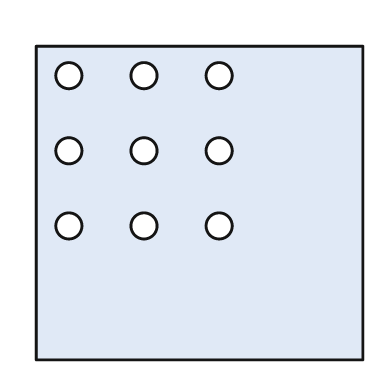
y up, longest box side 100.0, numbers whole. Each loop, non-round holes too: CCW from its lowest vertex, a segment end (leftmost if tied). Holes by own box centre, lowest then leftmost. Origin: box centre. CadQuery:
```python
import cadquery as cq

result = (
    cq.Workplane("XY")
    .moveTo(-50.0, -48.0)
    .lineTo(50.0, -48.0)
    .lineTo(50.0, 48.0)
    .lineTo(-50.0, 48.0)
    .close()
    .moveTo(-40.0, -7.0)
    .circle(4.0)
    .moveTo(-17.0, -7.0)
    .circle(4.0)
    .moveTo(6.0, -7.0)
    .circle(4.0)
    .moveTo(-40.0, 16.0)
    .circle(4.0)
    .moveTo(-17.0, 16.0)
    .circle(4.0)
    .moveTo(6.0, 16.0)
    .circle(4.0)
    .moveTo(-40.0, 39.0)
    .circle(4.0)
    .moveTo(-17.0, 39.0)
    .circle(4.0)
    .moveTo(6.0, 39.0)
    .circle(4.0)
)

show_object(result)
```